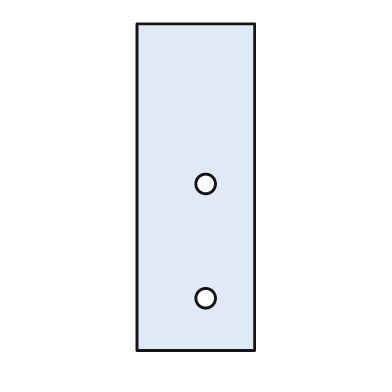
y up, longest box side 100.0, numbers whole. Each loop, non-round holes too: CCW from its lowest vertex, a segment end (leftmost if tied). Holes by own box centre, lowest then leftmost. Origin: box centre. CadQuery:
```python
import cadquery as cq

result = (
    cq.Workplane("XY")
    .moveTo(-18.0, -50.0)
    .lineTo(18.0, -50.0)
    .lineTo(18.0, 50.0)
    .lineTo(-18.0, 50.0)
    .close()
    .moveTo(3.0, -34.0)
    .circle(3.0)
    .moveTo(3.0, 1.0)
    .circle(3.0)
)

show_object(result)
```